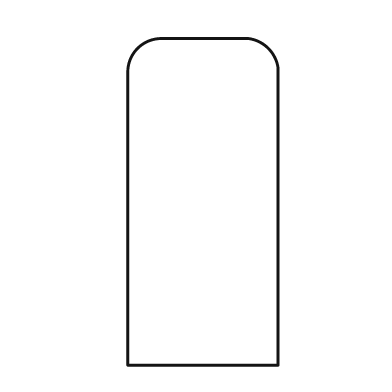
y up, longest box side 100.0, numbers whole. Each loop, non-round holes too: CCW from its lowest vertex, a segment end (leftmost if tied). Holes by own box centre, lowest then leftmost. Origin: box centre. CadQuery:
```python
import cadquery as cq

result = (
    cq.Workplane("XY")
    .moveTo(-23.0, -50.0)
    .lineTo(23.0, -50.0)
    .lineTo(23.0, 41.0)
    .threePointArc((20.0, 47.0), (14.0, 50.0))
    .lineTo(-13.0, 50.0)
    .threePointArc((-20.0, 47.0), (-23.0, 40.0))
    .close()
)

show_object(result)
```